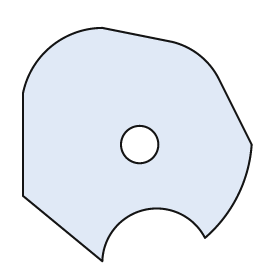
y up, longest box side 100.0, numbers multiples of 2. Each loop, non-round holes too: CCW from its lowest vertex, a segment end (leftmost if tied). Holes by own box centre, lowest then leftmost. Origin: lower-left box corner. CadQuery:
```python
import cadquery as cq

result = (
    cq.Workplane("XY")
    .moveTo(34.0, 0.0)
    .threePointArc((52.0, 22.0), (78.0, 10.0))
    .threePointArc((92.0, 28.0), (98.0, 50.0))
    .lineTo(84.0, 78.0)
    .threePointArc((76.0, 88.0), (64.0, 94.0))
    .lineTo(34.0, 100.0)
    .threePointArc((12.0, 92.0), (0.0, 72.0))
    .lineTo(0.0, 28.0)
    .close()
    .moveTo(50.0, 50.0)
    .circle(8.0)
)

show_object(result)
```